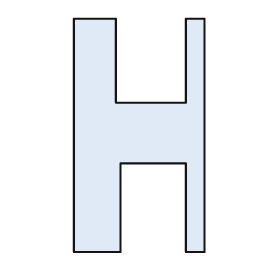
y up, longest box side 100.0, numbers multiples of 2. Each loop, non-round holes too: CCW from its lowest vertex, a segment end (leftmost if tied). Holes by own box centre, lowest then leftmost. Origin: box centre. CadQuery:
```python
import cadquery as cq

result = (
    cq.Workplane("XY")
    .moveTo(-28.0, -50.0)
    .lineTo(-8.0, -50.0)
    .lineTo(-8.0, -12.0)
    .lineTo(20.0, -12.0)
    .lineTo(20.0, -50.0)
    .lineTo(28.0, -50.0)
    .lineTo(28.0, 50.0)
    .lineTo(20.0, 50.0)
    .lineTo(20.0, 14.0)
    .lineTo(-10.0, 14.0)
    .lineTo(-10.0, 50.0)
    .lineTo(-28.0, 50.0)
    .close()
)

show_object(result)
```